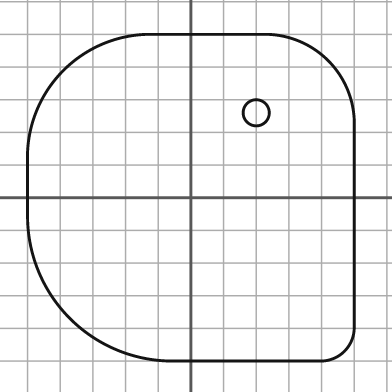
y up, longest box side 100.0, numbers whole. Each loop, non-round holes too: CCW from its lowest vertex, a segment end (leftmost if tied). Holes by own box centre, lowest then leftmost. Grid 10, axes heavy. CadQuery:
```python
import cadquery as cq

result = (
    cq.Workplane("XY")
    .moveTo(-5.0, -50.0)
    .lineTo(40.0, -50.0)
    .threePointArc((47.0, -47.0), (50.0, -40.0))
    .lineTo(50.0, 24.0)
    .threePointArc((42.0, 42.0), (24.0, 50.0))
    .lineTo(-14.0, 50.0)
    .threePointArc((-39.0, 39.0), (-50.0, 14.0))
    .lineTo(-50.0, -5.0)
    .threePointArc((-37.0, -37.0), (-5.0, -50.0))
    .close()
    .moveTo(20.0, 26.0)
    .circle(4.0)
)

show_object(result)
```